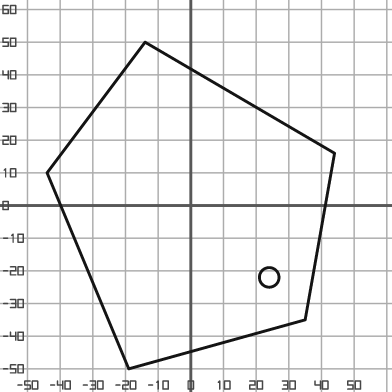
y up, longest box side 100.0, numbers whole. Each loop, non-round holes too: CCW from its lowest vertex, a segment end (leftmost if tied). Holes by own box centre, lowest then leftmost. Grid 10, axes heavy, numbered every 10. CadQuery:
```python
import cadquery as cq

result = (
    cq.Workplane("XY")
    .moveTo(-19.0, -50.0)
    .lineTo(35.0, -35.0)
    .lineTo(44.0, 16.0)
    .lineTo(-14.0, 50.0)
    .lineTo(-44.0, 10.0)
    .close()
    .moveTo(24.0, -22.0)
    .circle(3.0)
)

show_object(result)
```